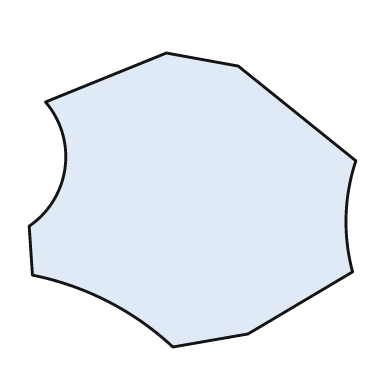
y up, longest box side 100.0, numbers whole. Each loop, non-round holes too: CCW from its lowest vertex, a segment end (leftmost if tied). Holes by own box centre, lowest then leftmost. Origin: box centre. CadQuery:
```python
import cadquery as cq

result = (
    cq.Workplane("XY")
    .moveTo(-6.0, -45.0)
    .lineTo(17.0, -41.0)
    .lineTo(49.0, -22.0)
    .threePointArc((47.0, -5.0), (50.0, 12.0))
    .lineTo(14.0, 41.0)
    .lineTo(-8.0, 45.0)
    .lineTo(-45.0, 30.0)
    .threePointArc((-39.0, 10.0), (-50.0, -8.0))
    .lineTo(-49.0, -23.0)
    .threePointArc((-26.0, -31.0), (-6.0, -45.0))
    .close()
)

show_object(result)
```